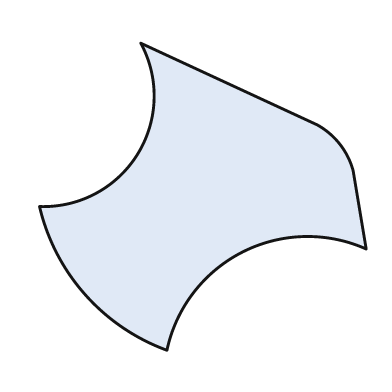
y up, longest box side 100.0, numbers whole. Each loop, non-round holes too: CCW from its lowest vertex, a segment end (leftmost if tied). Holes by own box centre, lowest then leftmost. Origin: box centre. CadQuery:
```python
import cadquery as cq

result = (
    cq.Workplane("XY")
    .moveTo(-11.0, -47.0)
    .threePointArc((12.0, -17.0), (50.0, -16.0))
    .lineTo(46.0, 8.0)
    .threePointArc((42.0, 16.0), (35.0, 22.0))
    .lineTo(-19.0, 47.0)
    .threePointArc((-20.0, 13.0), (-50.0, -3.0))
    .threePointArc((-36.0, -30.0), (-11.0, -47.0))
    .close()
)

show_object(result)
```